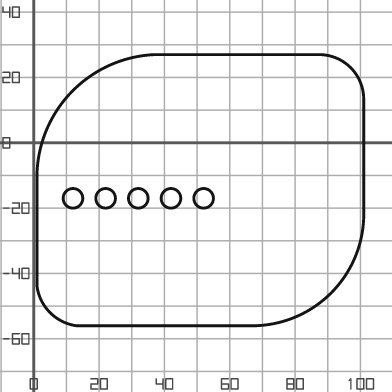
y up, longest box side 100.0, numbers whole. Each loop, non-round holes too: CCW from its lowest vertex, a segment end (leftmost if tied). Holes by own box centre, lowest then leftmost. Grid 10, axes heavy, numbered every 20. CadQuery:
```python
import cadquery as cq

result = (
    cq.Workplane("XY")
    .moveTo(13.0, -56.0)
    .lineTo(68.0, -56.0)
    .threePointArc((91.0, -46.0), (101.0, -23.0))
    .lineTo(101.0, 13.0)
    .threePointArc((97.0, 23.0), (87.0, 27.0))
    .lineTo(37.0, 27.0)
    .threePointArc((12.0, 16.0), (1.0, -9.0))
    .lineTo(1.0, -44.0)
    .threePointArc((5.0, -52.0), (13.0, -56.0))
    .close()
    .moveTo(12.0, -17.0)
    .circle(3.0)
    .moveTo(22.0, -17.0)
    .circle(3.0)
    .moveTo(32.0, -17.0)
    .circle(3.0)
    .moveTo(42.0, -17.0)
    .circle(3.0)
    .moveTo(52.0, -17.0)
    .circle(3.0)
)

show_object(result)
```